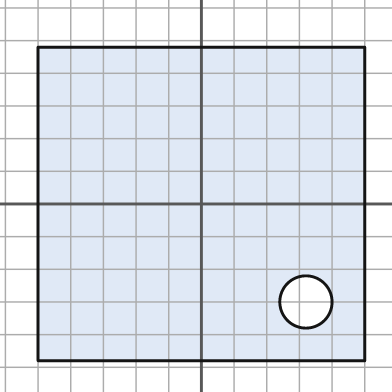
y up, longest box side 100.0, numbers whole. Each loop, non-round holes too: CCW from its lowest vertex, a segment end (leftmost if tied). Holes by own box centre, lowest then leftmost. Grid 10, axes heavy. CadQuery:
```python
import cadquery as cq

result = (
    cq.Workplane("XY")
    .moveTo(-50.0, -48.0)
    .lineTo(50.0, -48.0)
    .lineTo(50.0, 48.0)
    .lineTo(-50.0, 48.0)
    .close()
    .moveTo(32.0, -30.0)
    .circle(8.0)
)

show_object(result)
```